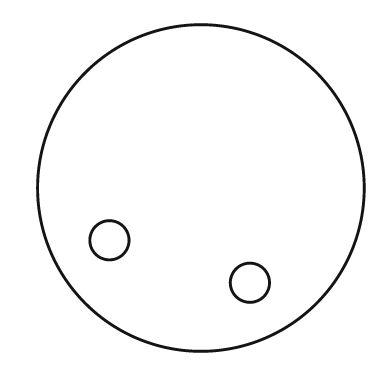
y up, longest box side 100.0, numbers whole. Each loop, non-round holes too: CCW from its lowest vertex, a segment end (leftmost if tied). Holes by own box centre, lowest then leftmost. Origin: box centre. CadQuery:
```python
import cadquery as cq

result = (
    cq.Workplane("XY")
    .moveTo(0.0, 0.0)
    .circle(50.0)
    .moveTo(15.0, -29.0)
    .circle(6.0)
    .moveTo(-28.0, -16.0)
    .circle(6.0)
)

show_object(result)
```